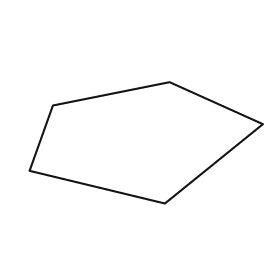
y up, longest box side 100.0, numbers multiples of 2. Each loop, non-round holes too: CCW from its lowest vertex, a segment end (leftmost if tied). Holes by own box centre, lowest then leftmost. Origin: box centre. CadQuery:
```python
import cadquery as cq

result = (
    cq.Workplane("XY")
    .moveTo(8.0, -26.0)
    .lineTo(50.0, 8.0)
    .lineTo(10.0, 26.0)
    .lineTo(-40.0, 16.0)
    .lineTo(-50.0, -12.0)
    .close()
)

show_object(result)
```